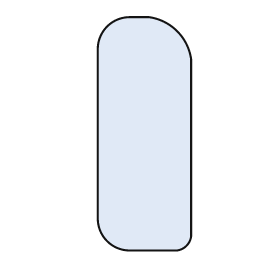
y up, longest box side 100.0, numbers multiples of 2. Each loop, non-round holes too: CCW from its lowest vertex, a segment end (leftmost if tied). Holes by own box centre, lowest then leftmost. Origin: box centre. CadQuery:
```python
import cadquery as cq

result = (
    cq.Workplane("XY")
    .moveTo(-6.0, -50.0)
    .lineTo(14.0, -50.0)
    .threePointArc((18.0, -48.0), (20.0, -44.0))
    .lineTo(20.0, 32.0)
    .threePointArc((14.0, 44.0), (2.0, 50.0))
    .lineTo(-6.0, 50.0)
    .threePointArc((-16.0, 46.0), (-20.0, 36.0))
    .lineTo(-20.0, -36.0)
    .threePointArc((-16.0, -46.0), (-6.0, -50.0))
    .close()
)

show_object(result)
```